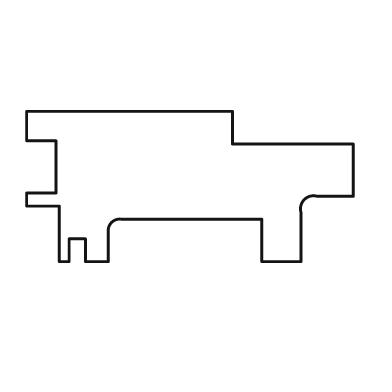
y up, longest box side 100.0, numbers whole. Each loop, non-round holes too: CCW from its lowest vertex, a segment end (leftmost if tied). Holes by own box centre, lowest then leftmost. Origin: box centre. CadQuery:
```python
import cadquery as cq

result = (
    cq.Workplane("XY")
    .moveTo(-40.0, -23.0)
    .lineTo(-37.0, -23.0)
    .lineTo(-37.0, -16.0)
    .lineTo(-32.0, -16.0)
    .lineTo(-32.0, -23.0)
    .lineTo(-25.0, -23.0)
    .lineTo(-25.0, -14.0)
    .threePointArc((-24.0, -11.0), (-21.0, -10.0))
    .lineTo(22.0, -10.0)
    .lineTo(22.0, -23.0)
    .lineTo(34.0, -23.0)
    .lineTo(34.0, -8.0)
    .threePointArc((35.0, -4.0), (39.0, -3.0))
    .lineTo(50.0, -3.0)
    .lineTo(50.0, 13.0)
    .lineTo(13.0, 13.0)
    .lineTo(13.0, 23.0)
    .lineTo(-50.0, 23.0)
    .lineTo(-50.0, 14.0)
    .lineTo(-41.0, 14.0)
    .lineTo(-41.0, -2.0)
    .lineTo(-50.0, -2.0)
    .lineTo(-50.0, -6.0)
    .lineTo(-40.0, -6.0)
    .close()
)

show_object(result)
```